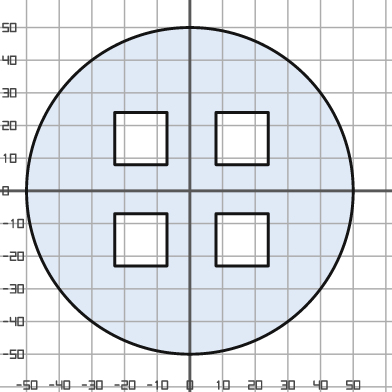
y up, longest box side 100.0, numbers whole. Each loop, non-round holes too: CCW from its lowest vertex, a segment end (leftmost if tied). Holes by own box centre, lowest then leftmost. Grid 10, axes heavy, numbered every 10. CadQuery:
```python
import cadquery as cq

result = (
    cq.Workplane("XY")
    .moveTo(0.0, 0.0)
    .circle(50.0)
    .moveTo(-23.0, -23.0)
    .lineTo(-7.0, -23.0)
    .lineTo(-7.0, -7.0)
    .lineTo(-23.0, -7.0)
    .close()
    .moveTo(8.0, -23.0)
    .lineTo(24.0, -23.0)
    .lineTo(24.0, -7.0)
    .lineTo(8.0, -7.0)
    .close()
    .moveTo(-23.0, 8.0)
    .lineTo(-7.0, 8.0)
    .lineTo(-7.0, 24.0)
    .lineTo(-23.0, 24.0)
    .close()
    .moveTo(8.0, 8.0)
    .lineTo(24.0, 8.0)
    .lineTo(24.0, 24.0)
    .lineTo(8.0, 24.0)
    .close()
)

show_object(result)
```